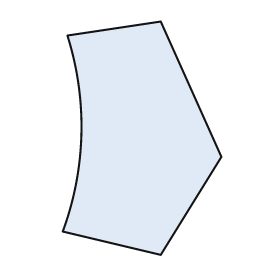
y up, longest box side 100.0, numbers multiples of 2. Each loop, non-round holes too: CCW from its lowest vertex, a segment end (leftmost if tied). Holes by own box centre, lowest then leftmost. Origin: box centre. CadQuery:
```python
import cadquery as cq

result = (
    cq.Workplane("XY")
    .moveTo(8.0, -50.0)
    .lineTo(34.0, -8.0)
    .lineTo(8.0, 50.0)
    .lineTo(-32.0, 44.0)
    .threePointArc((-26.0, 2.0), (-34.0, -40.0))
    .close()
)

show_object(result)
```